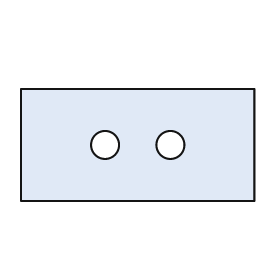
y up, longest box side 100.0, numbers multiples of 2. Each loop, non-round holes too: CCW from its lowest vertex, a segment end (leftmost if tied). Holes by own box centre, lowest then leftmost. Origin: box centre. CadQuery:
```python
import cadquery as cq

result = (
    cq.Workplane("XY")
    .moveTo(-50.0, -24.0)
    .lineTo(50.0, -24.0)
    .lineTo(50.0, 24.0)
    .lineTo(-50.0, 24.0)
    .close()
    .moveTo(-14.0, 0.0)
    .circle(6.0)
    .moveTo(14.0, 0.0)
    .circle(6.0)
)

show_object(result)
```